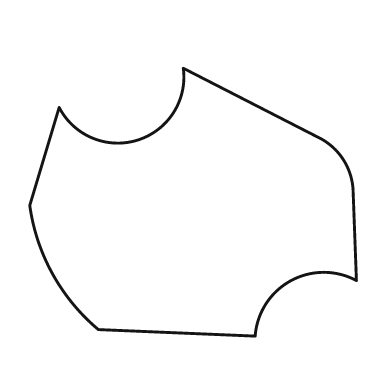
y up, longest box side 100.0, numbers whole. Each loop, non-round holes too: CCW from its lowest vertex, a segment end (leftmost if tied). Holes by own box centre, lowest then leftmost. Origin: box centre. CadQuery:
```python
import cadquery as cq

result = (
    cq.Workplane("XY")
    .moveTo(19.0, -41.0)
    .threePointArc((30.0, -24.0), (50.0, -24.0))
    .lineTo(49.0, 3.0)
    .threePointArc((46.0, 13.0), (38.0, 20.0))
    .lineTo(-3.0, 41.0)
    .threePointArc((-17.0, 19.0), (-41.0, 29.0))
    .lineTo(-50.0, -1.0)
    .threePointArc((-43.0, -22.0), (-29.0, -39.0))
    .close()
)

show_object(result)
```